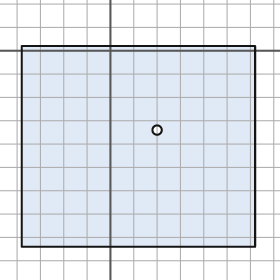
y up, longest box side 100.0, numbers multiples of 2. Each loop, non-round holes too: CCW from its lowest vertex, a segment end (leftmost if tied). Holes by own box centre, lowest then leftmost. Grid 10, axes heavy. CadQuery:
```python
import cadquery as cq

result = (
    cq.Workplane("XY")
    .moveTo(-38.0, -84.0)
    .lineTo(62.0, -84.0)
    .lineTo(62.0, 2.0)
    .lineTo(-38.0, 2.0)
    .close()
    .moveTo(20.0, -34.0)
    .circle(2.0)
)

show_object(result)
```